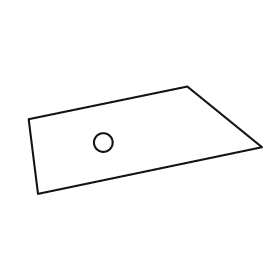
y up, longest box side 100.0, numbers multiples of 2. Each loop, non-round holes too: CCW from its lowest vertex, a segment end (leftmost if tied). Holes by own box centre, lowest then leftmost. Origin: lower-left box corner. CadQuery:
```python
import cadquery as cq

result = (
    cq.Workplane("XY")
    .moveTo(4.0, 0.0)
    .lineTo(100.0, 20.0)
    .lineTo(68.0, 46.0)
    .lineTo(0.0, 32.0)
    .close()
    .moveTo(32.0, 22.0)
    .circle(4.0)
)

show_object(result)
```